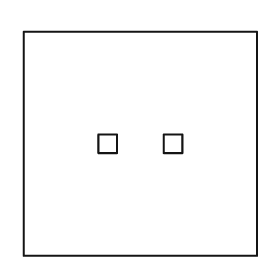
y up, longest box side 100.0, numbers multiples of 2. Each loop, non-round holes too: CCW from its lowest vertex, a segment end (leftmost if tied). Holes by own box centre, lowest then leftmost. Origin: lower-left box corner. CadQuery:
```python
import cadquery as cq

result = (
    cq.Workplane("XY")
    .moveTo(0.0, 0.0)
    .lineTo(100.0, 0.0)
    .lineTo(100.0, 96.0)
    .lineTo(0.0, 96.0)
    .close()
    .moveTo(32.0, 44.0)
    .lineTo(40.0, 44.0)
    .lineTo(40.0, 52.0)
    .lineTo(32.0, 52.0)
    .close()
    .moveTo(60.0, 44.0)
    .lineTo(68.0, 44.0)
    .lineTo(68.0, 52.0)
    .lineTo(60.0, 52.0)
    .close()
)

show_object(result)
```